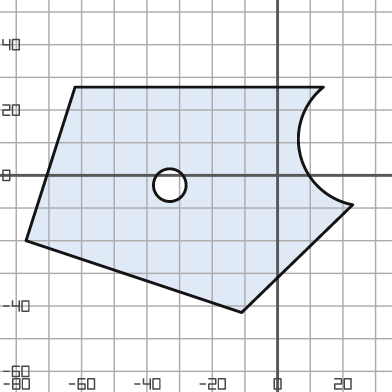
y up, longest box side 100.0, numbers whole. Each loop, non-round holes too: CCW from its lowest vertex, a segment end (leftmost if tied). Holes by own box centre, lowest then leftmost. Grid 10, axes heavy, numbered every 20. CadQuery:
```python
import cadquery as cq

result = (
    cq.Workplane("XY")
    .moveTo(-11.0, -42.0)
    .lineTo(23.0, -9.0)
    .threePointArc((7.0, 6.0), (14.0, 27.0))
    .lineTo(-62.0, 27.0)
    .lineTo(-77.0, -20.0)
    .close()
    .moveTo(-33.0, -3.0)
    .circle(5.0)
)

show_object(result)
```